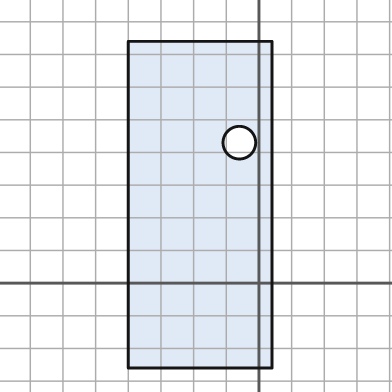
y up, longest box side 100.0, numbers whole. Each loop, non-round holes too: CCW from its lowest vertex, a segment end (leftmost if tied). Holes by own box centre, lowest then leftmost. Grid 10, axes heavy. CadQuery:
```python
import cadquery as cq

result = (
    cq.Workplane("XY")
    .moveTo(-40.0, -26.0)
    .lineTo(4.0, -26.0)
    .lineTo(4.0, 74.0)
    .lineTo(-40.0, 74.0)
    .close()
    .moveTo(-6.0, 43.0)
    .circle(5.0)
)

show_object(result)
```